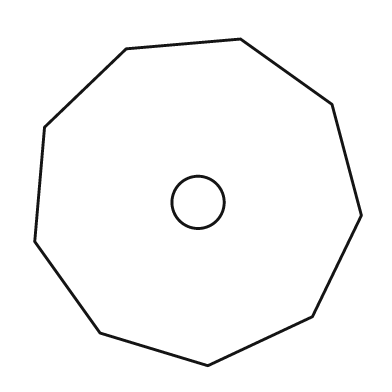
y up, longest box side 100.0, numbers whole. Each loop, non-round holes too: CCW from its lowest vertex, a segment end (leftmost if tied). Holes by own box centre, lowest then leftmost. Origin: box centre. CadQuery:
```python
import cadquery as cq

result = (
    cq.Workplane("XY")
    .moveTo(3.0, -50.0)
    .lineTo(35.0, -35.0)
    .lineTo(50.0, -4.0)
    .lineTo(41.0, 30.0)
    .lineTo(13.0, 50.0)
    .lineTo(-22.0, 47.0)
    .lineTo(-47.0, 23.0)
    .lineTo(-50.0, -12.0)
    .lineTo(-30.0, -40.0)
    .close()
    .moveTo(0.0, 0.0)
    .circle(8.0)
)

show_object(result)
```